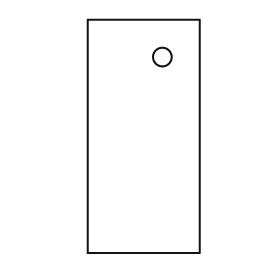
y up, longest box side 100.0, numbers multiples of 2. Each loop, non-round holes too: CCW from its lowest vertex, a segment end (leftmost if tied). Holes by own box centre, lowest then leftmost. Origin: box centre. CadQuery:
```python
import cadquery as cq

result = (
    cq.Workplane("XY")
    .moveTo(-24.0, -50.0)
    .lineTo(24.0, -50.0)
    .lineTo(24.0, 50.0)
    .lineTo(-24.0, 50.0)
    .close()
    .moveTo(8.0, 34.0)
    .circle(4.0)
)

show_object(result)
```